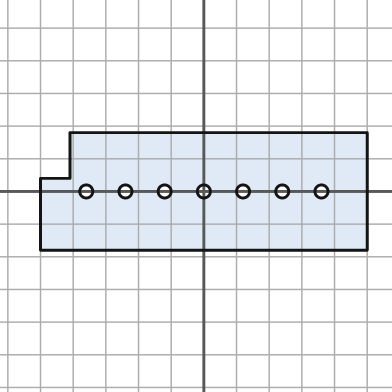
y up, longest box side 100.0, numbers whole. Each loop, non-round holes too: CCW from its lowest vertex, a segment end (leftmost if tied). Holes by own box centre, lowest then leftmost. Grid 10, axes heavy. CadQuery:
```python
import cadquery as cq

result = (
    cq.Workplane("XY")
    .moveTo(-50.0, -18.0)
    .lineTo(50.0, -18.0)
    .lineTo(50.0, 18.0)
    .lineTo(-41.0, 18.0)
    .lineTo(-41.0, 4.0)
    .lineTo(-50.0, 4.0)
    .close()
    .moveTo(-36.0, 0.0)
    .circle(2.0)
    .moveTo(-24.0, 0.0)
    .circle(2.0)
    .moveTo(-12.0, 0.0)
    .circle(2.0)
    .moveTo(0.0, 0.0)
    .circle(2.0)
    .moveTo(12.0, 0.0)
    .circle(2.0)
    .moveTo(24.0, 0.0)
    .circle(2.0)
    .moveTo(36.0, 0.0)
    .circle(2.0)
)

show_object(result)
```